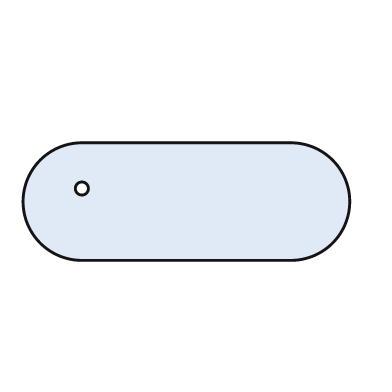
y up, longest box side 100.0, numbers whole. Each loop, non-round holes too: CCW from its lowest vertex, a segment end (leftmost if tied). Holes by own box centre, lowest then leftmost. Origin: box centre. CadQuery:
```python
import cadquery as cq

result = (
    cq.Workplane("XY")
    .moveTo(-32.0, -18.0)
    .lineTo(32.0, -18.0)
    .threePointArc((50.0, 0.0), (32.0, 18.0))
    .lineTo(-32.0, 18.0)
    .threePointArc((-50.0, 0.0), (-32.0, -18.0))
    .close()
    .moveTo(-32.0, 4.0)
    .circle(2.0)
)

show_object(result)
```